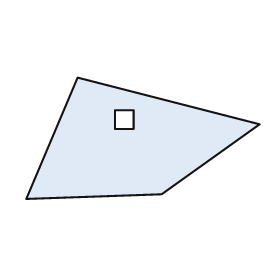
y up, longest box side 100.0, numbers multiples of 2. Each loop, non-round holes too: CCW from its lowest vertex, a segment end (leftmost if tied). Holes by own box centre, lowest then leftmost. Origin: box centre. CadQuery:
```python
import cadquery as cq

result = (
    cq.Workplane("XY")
    .moveTo(-50.0, -26.0)
    .lineTo(8.0, -24.0)
    .lineTo(50.0, 6.0)
    .lineTo(-28.0, 26.0)
    .close()
    .moveTo(-12.0, 4.0)
    .lineTo(-4.0, 4.0)
    .lineTo(-4.0, 12.0)
    .lineTo(-12.0, 12.0)
    .close()
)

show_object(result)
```